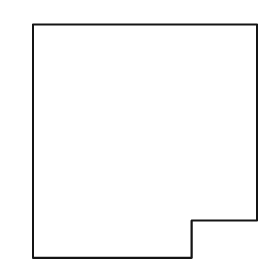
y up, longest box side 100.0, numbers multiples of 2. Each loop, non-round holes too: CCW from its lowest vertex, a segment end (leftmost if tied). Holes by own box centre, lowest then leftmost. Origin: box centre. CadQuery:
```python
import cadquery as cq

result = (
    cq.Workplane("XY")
    .moveTo(-48.0, -50.0)
    .lineTo(20.0, -50.0)
    .lineTo(20.0, -34.0)
    .lineTo(48.0, -34.0)
    .lineTo(48.0, 50.0)
    .lineTo(-48.0, 50.0)
    .close()
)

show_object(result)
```